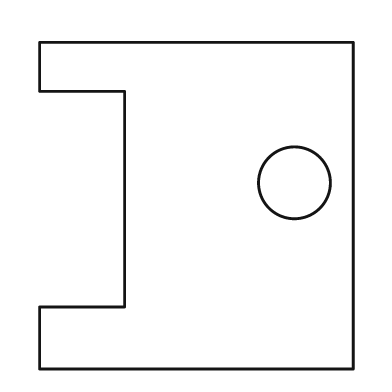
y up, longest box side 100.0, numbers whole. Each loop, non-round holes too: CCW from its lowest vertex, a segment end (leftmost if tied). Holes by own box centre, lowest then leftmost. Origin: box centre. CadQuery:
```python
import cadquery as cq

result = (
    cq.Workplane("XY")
    .moveTo(-48.0, -50.0)
    .lineTo(48.0, -50.0)
    .lineTo(48.0, 50.0)
    .lineTo(-48.0, 50.0)
    .lineTo(-48.0, 35.0)
    .lineTo(-22.0, 35.0)
    .lineTo(-22.0, -31.0)
    .lineTo(-48.0, -31.0)
    .close()
    .moveTo(30.0, 7.0)
    .circle(11.0)
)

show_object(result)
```